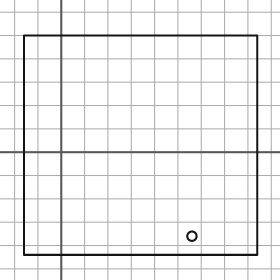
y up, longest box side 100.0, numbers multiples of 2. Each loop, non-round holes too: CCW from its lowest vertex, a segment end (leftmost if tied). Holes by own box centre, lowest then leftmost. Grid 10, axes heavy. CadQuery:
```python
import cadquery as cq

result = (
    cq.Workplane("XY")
    .moveTo(-16.0, -44.0)
    .lineTo(84.0, -44.0)
    .lineTo(84.0, 50.0)
    .lineTo(-16.0, 50.0)
    .close()
    .moveTo(56.0, -36.0)
    .circle(2.0)
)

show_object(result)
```